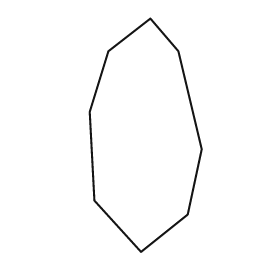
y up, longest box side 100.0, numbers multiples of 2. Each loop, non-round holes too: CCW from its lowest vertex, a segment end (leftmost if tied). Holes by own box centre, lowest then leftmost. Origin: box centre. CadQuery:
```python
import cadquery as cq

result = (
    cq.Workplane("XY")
    .moveTo(-2.0, -50.0)
    .lineTo(18.0, -34.0)
    .lineTo(24.0, -6.0)
    .lineTo(14.0, 36.0)
    .lineTo(2.0, 50.0)
    .lineTo(-16.0, 36.0)
    .lineTo(-24.0, 10.0)
    .lineTo(-22.0, -28.0)
    .close()
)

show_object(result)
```